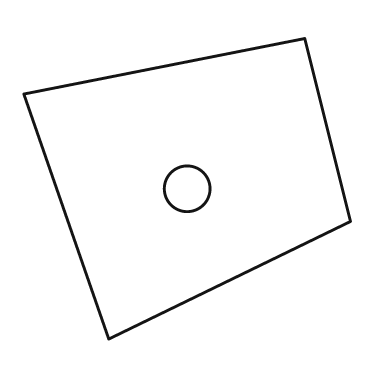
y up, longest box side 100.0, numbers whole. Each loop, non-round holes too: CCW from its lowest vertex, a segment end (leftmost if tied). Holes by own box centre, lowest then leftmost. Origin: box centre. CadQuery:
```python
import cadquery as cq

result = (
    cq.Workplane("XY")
    .moveTo(-24.0, -46.0)
    .lineTo(50.0, -10.0)
    .lineTo(36.0, 46.0)
    .lineTo(-50.0, 29.0)
    .close()
    .moveTo(0.0, 0.0)
    .circle(7.0)
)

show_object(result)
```